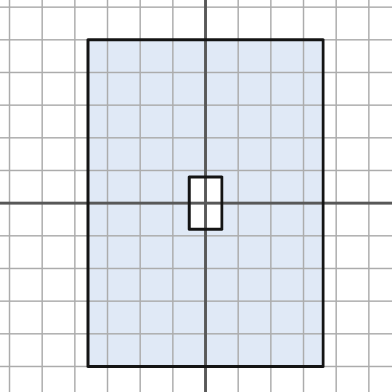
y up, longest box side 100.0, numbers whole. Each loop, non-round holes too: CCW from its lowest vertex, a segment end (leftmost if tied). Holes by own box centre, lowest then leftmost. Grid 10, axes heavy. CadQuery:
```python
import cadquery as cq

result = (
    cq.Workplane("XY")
    .moveTo(-36.0, -50.0)
    .lineTo(36.0, -50.0)
    .lineTo(36.0, 50.0)
    .lineTo(-36.0, 50.0)
    .close()
    .moveTo(-5.0, -8.0)
    .lineTo(5.0, -8.0)
    .lineTo(5.0, 8.0)
    .lineTo(-5.0, 8.0)
    .close()
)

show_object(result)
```